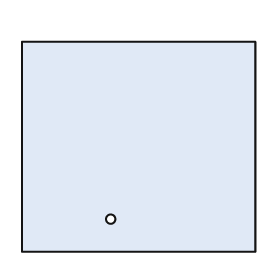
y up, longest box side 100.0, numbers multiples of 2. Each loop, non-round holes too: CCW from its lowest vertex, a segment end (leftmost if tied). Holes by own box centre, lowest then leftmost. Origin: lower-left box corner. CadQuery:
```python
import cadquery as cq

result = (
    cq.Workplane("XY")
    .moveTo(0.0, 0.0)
    .lineTo(100.0, 0.0)
    .lineTo(100.0, 90.0)
    .lineTo(0.0, 90.0)
    .close()
    .moveTo(38.0, 14.0)
    .circle(2.0)
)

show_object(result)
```